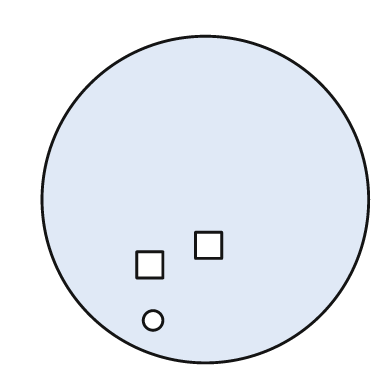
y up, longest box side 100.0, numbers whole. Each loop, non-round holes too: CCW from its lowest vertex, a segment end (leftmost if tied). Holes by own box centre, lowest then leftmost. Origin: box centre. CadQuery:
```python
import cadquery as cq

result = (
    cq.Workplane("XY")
    .moveTo(0.0, 0.0)
    .circle(50.0)
    .moveTo(-16.0, -37.0)
    .circle(3.0)
    .moveTo(-21.0, -24.0)
    .lineTo(-13.0, -24.0)
    .lineTo(-13.0, -16.0)
    .lineTo(-21.0, -16.0)
    .close()
    .moveTo(-3.0, -18.0)
    .lineTo(5.0, -18.0)
    .lineTo(5.0, -10.0)
    .lineTo(-3.0, -10.0)
    .close()
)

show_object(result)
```